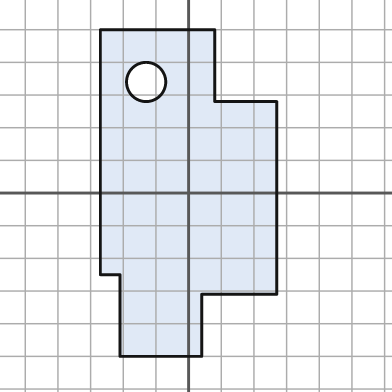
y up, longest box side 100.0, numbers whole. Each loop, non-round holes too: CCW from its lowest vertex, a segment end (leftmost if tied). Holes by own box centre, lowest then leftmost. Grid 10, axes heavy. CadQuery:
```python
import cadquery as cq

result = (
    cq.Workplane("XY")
    .moveTo(-21.0, -50.0)
    .lineTo(4.0, -50.0)
    .lineTo(4.0, -31.0)
    .lineTo(27.0, -31.0)
    .lineTo(27.0, 28.0)
    .lineTo(8.0, 28.0)
    .lineTo(8.0, 50.0)
    .lineTo(-27.0, 50.0)
    .lineTo(-27.0, -25.0)
    .lineTo(-21.0, -25.0)
    .close()
    .moveTo(-13.0, 34.0)
    .circle(6.0)
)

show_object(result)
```